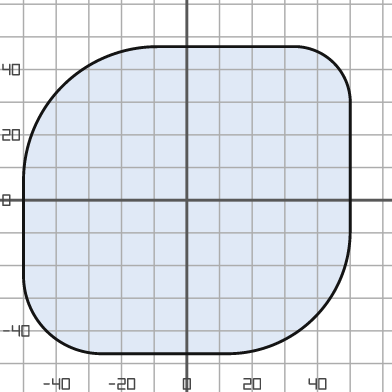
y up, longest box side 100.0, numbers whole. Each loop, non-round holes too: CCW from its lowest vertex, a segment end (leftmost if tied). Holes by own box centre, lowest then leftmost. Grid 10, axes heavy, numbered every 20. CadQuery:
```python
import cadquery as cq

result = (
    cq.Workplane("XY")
    .moveTo(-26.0, -47.0)
    .lineTo(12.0, -47.0)
    .threePointArc((39.0, -36.0), (50.0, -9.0))
    .lineTo(50.0, 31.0)
    .threePointArc((45.0, 42.0), (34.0, 47.0))
    .lineTo(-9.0, 47.0)
    .threePointArc((-38.0, 35.0), (-50.0, 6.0))
    .lineTo(-50.0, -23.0)
    .threePointArc((-43.0, -40.0), (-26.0, -47.0))
    .close()
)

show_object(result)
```